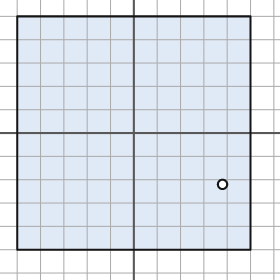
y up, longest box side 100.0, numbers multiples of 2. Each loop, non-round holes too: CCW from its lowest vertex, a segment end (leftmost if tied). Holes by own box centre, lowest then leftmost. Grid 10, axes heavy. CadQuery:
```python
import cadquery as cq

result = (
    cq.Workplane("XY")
    .moveTo(-50.0, -50.0)
    .lineTo(50.0, -50.0)
    .lineTo(50.0, 50.0)
    .lineTo(-50.0, 50.0)
    .close()
    .moveTo(38.0, -22.0)
    .circle(2.0)
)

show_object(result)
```